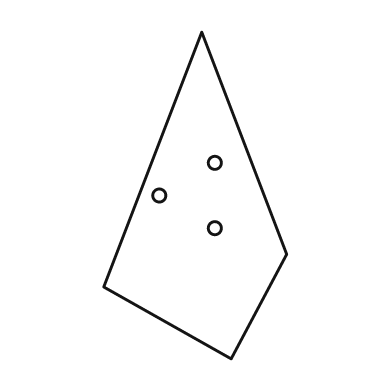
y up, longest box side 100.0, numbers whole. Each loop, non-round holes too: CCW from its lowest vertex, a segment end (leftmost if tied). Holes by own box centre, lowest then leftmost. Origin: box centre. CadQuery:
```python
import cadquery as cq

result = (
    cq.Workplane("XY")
    .moveTo(11.0, -50.0)
    .lineTo(28.0, -18.0)
    .lineTo(2.0, 50.0)
    .lineTo(-28.0, -28.0)
    .close()
    .moveTo(6.0, -10.0)
    .circle(2.0)
    .moveTo(-11.0, 0.0)
    .circle(2.0)
    .moveTo(6.0, 10.0)
    .circle(2.0)
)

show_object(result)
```